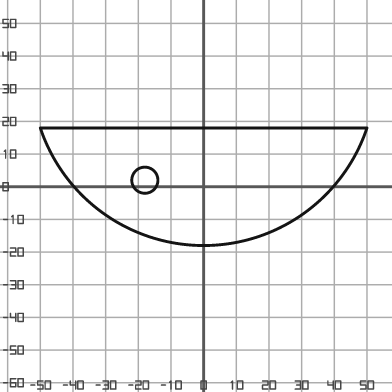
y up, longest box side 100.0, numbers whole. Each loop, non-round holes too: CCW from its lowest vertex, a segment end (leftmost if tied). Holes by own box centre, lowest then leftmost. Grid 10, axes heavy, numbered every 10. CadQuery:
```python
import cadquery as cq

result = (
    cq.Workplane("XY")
    .moveTo(-50.0, 18.0)
    .threePointArc((0.0, -18.0), (50.0, 18.0))
    .close()
    .moveTo(-18.0, 2.0)
    .circle(4.0)
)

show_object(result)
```